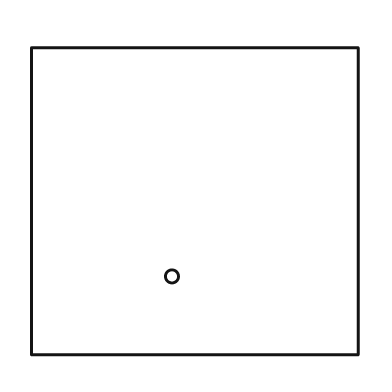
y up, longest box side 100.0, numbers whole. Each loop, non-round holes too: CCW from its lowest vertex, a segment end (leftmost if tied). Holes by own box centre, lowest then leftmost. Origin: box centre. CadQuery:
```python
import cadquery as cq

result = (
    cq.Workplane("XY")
    .moveTo(-50.0, -47.0)
    .lineTo(50.0, -47.0)
    .lineTo(50.0, 47.0)
    .lineTo(-50.0, 47.0)
    .close()
    .moveTo(-7.0, -23.0)
    .circle(2.0)
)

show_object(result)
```